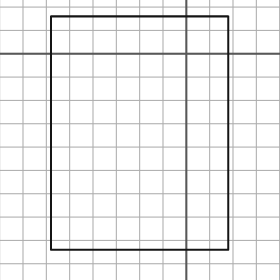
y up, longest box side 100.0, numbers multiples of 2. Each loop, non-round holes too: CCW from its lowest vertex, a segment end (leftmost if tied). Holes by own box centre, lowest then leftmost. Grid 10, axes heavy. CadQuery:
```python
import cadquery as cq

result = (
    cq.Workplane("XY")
    .moveTo(-58.0, -84.0)
    .lineTo(18.0, -84.0)
    .lineTo(18.0, 16.0)
    .lineTo(-58.0, 16.0)
    .close()
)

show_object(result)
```